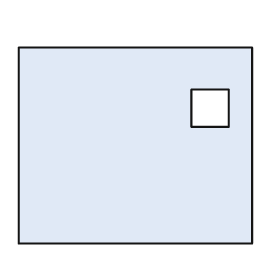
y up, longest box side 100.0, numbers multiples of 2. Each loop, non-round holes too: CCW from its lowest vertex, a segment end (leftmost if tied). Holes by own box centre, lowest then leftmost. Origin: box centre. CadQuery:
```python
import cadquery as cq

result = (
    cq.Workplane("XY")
    .moveTo(-50.0, -42.0)
    .lineTo(50.0, -42.0)
    .lineTo(50.0, 42.0)
    .lineTo(-50.0, 42.0)
    .close()
    .moveTo(24.0, 8.0)
    .lineTo(40.0, 8.0)
    .lineTo(40.0, 24.0)
    .lineTo(24.0, 24.0)
    .close()
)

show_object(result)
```